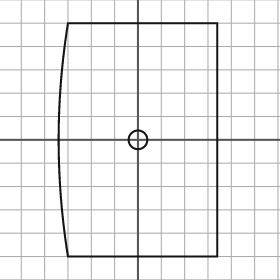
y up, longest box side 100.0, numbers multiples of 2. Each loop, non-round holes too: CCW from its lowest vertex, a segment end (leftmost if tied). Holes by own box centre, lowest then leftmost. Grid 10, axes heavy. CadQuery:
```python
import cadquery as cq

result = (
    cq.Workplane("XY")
    .moveTo(-30.0, -50.0)
    .lineTo(34.0, -50.0)
    .lineTo(34.0, 50.0)
    .lineTo(-30.0, 50.0)
    .threePointArc((-34.0, 0.0), (-30.0, -50.0))
    .close()
    .moveTo(0.0, 0.0)
    .circle(4.0)
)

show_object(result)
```